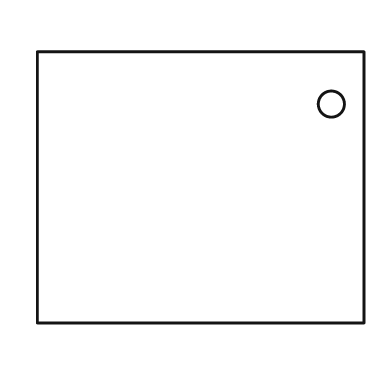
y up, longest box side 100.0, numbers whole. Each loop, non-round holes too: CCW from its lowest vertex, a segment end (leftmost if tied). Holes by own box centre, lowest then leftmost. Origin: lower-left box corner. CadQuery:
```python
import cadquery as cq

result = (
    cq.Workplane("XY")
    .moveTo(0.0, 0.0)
    .lineTo(100.0, 0.0)
    .lineTo(100.0, 83.0)
    .lineTo(0.0, 83.0)
    .close()
    .moveTo(90.0, 67.0)
    .circle(4.0)
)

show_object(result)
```